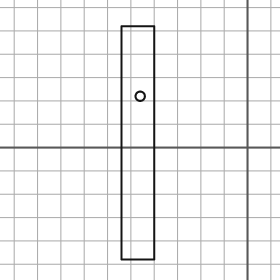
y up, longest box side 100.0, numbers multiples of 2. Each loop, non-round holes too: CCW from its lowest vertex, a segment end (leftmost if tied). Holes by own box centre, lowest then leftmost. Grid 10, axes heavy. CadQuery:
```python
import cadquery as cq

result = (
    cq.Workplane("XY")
    .moveTo(-54.0, -48.0)
    .lineTo(-40.0, -48.0)
    .lineTo(-40.0, 52.0)
    .lineTo(-54.0, 52.0)
    .close()
    .moveTo(-46.0, 22.0)
    .circle(2.0)
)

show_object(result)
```